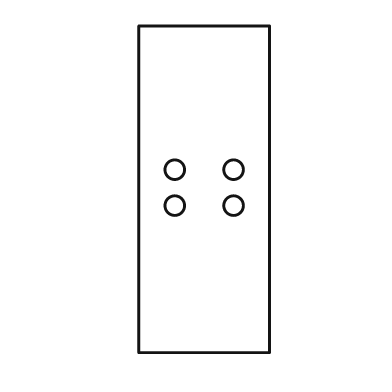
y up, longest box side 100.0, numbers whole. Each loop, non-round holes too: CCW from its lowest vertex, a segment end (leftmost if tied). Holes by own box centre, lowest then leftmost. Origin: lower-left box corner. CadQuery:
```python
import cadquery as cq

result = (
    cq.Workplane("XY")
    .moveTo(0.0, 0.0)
    .lineTo(40.0, 0.0)
    .lineTo(40.0, 100.0)
    .lineTo(0.0, 100.0)
    .close()
    .moveTo(11.0, 45.0)
    .circle(3.0)
    .moveTo(29.0, 45.0)
    .circle(3.0)
    .moveTo(11.0, 56.0)
    .circle(3.0)
    .moveTo(29.0, 56.0)
    .circle(3.0)
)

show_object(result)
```